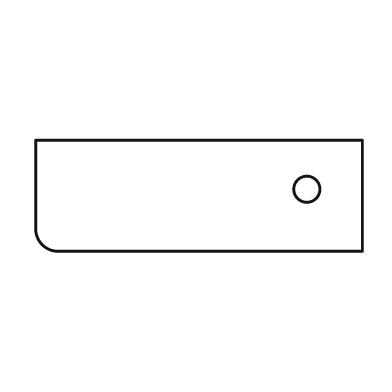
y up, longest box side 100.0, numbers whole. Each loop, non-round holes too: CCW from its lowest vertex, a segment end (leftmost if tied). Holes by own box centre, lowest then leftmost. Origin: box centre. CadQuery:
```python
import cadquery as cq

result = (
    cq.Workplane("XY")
    .moveTo(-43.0, -17.0)
    .lineTo(50.0, -17.0)
    .lineTo(50.0, 17.0)
    .lineTo(-50.0, 17.0)
    .lineTo(-50.0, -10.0)
    .threePointArc((-48.0, -15.0), (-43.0, -17.0))
    .close()
    .moveTo(33.0, 2.0)
    .circle(4.0)
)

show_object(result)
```